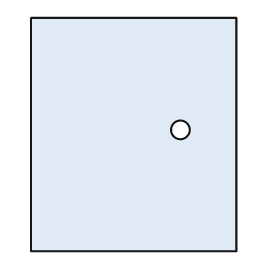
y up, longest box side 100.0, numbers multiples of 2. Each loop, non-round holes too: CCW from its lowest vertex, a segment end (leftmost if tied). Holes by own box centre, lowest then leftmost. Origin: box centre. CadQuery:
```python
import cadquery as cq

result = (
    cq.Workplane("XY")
    .moveTo(-44.0, -50.0)
    .lineTo(44.0, -50.0)
    .lineTo(44.0, 50.0)
    .lineTo(-44.0, 50.0)
    .close()
    .moveTo(20.0, 2.0)
    .circle(4.0)
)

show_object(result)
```